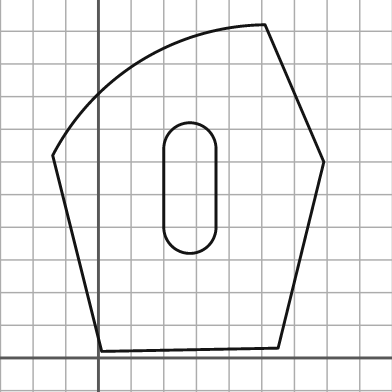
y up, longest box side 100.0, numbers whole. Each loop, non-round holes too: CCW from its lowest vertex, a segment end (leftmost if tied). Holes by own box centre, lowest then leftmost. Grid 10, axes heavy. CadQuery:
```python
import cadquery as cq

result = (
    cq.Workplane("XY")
    .moveTo(1.0, 2.0)
    .lineTo(55.0, 3.0)
    .lineTo(69.0, 60.0)
    .lineTo(51.0, 102.0)
    .threePointArc((13.0, 91.0), (-14.0, 62.0))
    .close()
    .moveTo(20.0, 40.0)
    .threePointArc((28.0, 32.0), (36.0, 40.0))
    .lineTo(36.0, 64.0)
    .threePointArc((28.0, 72.0), (20.0, 64.0))
    .close()
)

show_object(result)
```